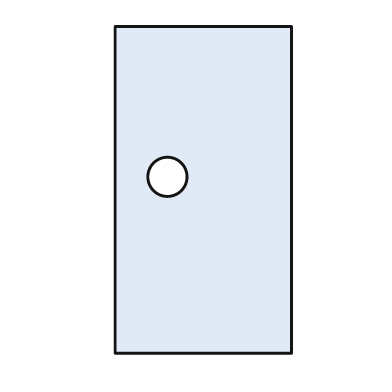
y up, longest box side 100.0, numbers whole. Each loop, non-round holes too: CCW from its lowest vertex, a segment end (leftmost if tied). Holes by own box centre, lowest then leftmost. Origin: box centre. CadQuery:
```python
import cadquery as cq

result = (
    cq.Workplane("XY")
    .moveTo(-27.0, -50.0)
    .lineTo(27.0, -50.0)
    .lineTo(27.0, 50.0)
    .lineTo(-27.0, 50.0)
    .close()
    .moveTo(-11.0, 4.0)
    .circle(6.0)
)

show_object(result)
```